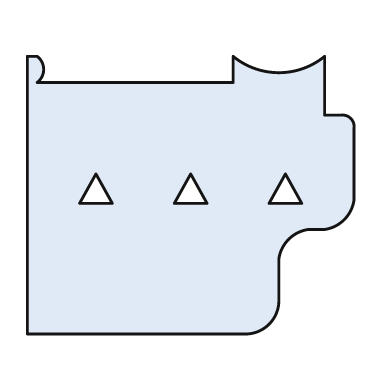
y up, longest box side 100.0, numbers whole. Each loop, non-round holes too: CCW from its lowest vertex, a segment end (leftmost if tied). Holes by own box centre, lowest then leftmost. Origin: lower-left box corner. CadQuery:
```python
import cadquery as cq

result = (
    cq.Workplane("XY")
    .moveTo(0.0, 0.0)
    .lineTo(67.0, 0.0)
    .threePointArc((74.0, 3.0), (77.0, 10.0))
    .lineTo(77.0, 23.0)
    .threePointArc((80.0, 29.0), (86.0, 32.0))
    .lineTo(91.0, 32.0)
    .threePointArc((97.0, 35.0), (100.0, 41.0))
    .lineTo(100.0, 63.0)
    .threePointArc((99.0, 66.0), (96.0, 67.0))
    .lineTo(91.0, 67.0)
    .lineTo(91.0, 85.0)
    .threePointArc((77.0, 80.0), (63.0, 85.0))
    .lineTo(63.0, 77.0)
    .lineTo(3.0, 77.0)
    .threePointArc((5.0, 81.0), (3.0, 85.0))
    .lineTo(0.0, 85.0)
    .close()
    .moveTo(16.0, 40.0)
    .lineTo(26.0, 40.0)
    .lineTo(21.0, 49.0)
    .close()
    .moveTo(45.0, 40.0)
    .lineTo(55.0, 40.0)
    .lineTo(50.0, 49.0)
    .close()
    .moveTo(74.0, 40.0)
    .lineTo(84.0, 40.0)
    .lineTo(79.0, 49.0)
    .close()
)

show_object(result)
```